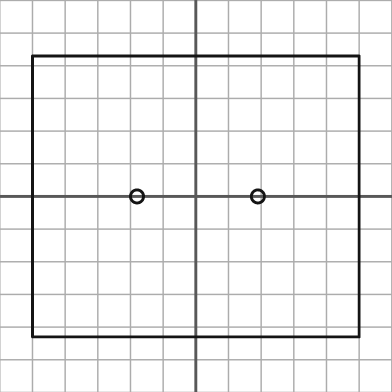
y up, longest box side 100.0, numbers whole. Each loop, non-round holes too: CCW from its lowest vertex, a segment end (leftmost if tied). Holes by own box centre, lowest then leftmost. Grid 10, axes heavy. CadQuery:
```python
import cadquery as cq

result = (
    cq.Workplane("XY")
    .moveTo(-50.0, -43.0)
    .lineTo(50.0, -43.0)
    .lineTo(50.0, 43.0)
    .lineTo(-50.0, 43.0)
    .close()
    .moveTo(-18.0, 0.0)
    .circle(2.0)
    .moveTo(19.0, 0.0)
    .circle(2.0)
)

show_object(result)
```